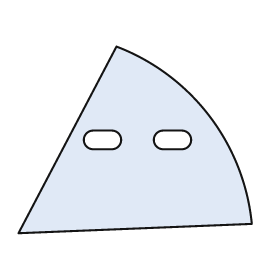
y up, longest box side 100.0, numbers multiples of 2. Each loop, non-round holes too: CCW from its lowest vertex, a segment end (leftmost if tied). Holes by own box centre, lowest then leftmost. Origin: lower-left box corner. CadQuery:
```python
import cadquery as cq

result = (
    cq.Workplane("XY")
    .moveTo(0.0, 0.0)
    .lineTo(100.0, 4.0)
    .threePointArc((82.0, 50.0), (42.0, 80.0))
    .close()
    .moveTo(32.0, 36.0)
    .lineTo(40.0, 36.0)
    .threePointArc((44.0, 40.0), (40.0, 44.0))
    .lineTo(32.0, 44.0)
    .threePointArc((28.0, 40.0), (32.0, 36.0))
    .close()
    .moveTo(62.0, 36.0)
    .lineTo(70.0, 36.0)
    .threePointArc((74.0, 40.0), (70.0, 44.0))
    .lineTo(62.0, 44.0)
    .threePointArc((58.0, 40.0), (62.0, 36.0))
    .close()
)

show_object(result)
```